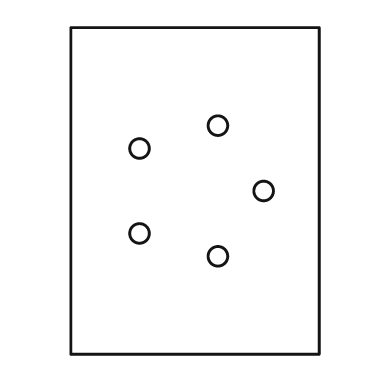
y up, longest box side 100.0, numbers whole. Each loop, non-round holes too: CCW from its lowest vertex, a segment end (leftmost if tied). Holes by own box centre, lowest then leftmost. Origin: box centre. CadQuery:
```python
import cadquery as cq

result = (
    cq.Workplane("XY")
    .moveTo(-38.0, -50.0)
    .lineTo(38.0, -50.0)
    .lineTo(38.0, 50.0)
    .lineTo(-38.0, 50.0)
    .close()
    .moveTo(7.0, -20.0)
    .circle(3.0)
    .moveTo(-17.0, -13.0)
    .circle(3.0)
    .moveTo(21.0, 0.0)
    .circle(3.0)
    .moveTo(-17.0, 13.0)
    .circle(3.0)
    .moveTo(7.0, 20.0)
    .circle(3.0)
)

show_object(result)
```